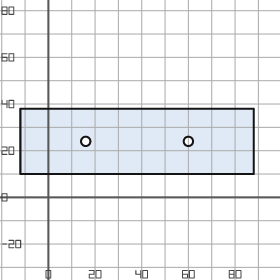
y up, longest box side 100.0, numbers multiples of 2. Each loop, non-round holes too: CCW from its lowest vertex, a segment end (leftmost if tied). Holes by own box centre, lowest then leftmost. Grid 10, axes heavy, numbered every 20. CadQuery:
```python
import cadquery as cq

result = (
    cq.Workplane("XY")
    .moveTo(-12.0, 10.0)
    .lineTo(88.0, 10.0)
    .lineTo(88.0, 38.0)
    .lineTo(-12.0, 38.0)
    .close()
    .moveTo(16.0, 24.0)
    .circle(2.0)
    .moveTo(60.0, 24.0)
    .circle(2.0)
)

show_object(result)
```